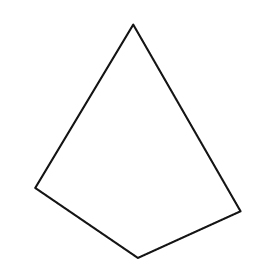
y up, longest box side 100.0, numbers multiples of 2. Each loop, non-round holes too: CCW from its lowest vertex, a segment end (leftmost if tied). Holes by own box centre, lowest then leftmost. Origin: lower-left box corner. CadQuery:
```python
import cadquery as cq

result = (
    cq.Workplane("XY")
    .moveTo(44.0, 0.0)
    .lineTo(88.0, 20.0)
    .lineTo(42.0, 100.0)
    .lineTo(0.0, 30.0)
    .close()
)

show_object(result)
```